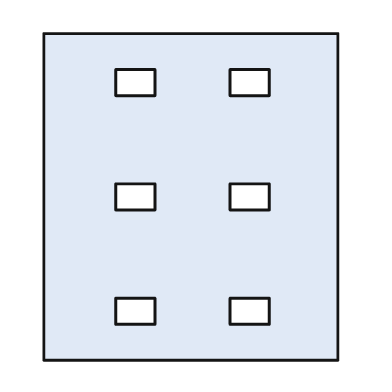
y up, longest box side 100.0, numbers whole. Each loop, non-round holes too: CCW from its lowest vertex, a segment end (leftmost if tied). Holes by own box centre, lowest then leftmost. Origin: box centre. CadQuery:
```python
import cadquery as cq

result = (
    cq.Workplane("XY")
    .moveTo(-45.0, -50.0)
    .lineTo(45.0, -50.0)
    .lineTo(45.0, 50.0)
    .lineTo(-45.0, 50.0)
    .close()
    .moveTo(-23.0, -39.0)
    .lineTo(-11.0, -39.0)
    .lineTo(-11.0, -31.0)
    .lineTo(-23.0, -31.0)
    .close()
    .moveTo(12.0, -39.0)
    .lineTo(24.0, -39.0)
    .lineTo(24.0, -31.0)
    .lineTo(12.0, -31.0)
    .close()
    .moveTo(-23.0, -4.0)
    .lineTo(-11.0, -4.0)
    .lineTo(-11.0, 4.0)
    .lineTo(-23.0, 4.0)
    .close()
    .moveTo(12.0, -4.0)
    .lineTo(24.0, -4.0)
    .lineTo(24.0, 4.0)
    .lineTo(12.0, 4.0)
    .close()
    .moveTo(-23.0, 31.0)
    .lineTo(-11.0, 31.0)
    .lineTo(-11.0, 39.0)
    .lineTo(-23.0, 39.0)
    .close()
    .moveTo(12.0, 31.0)
    .lineTo(24.0, 31.0)
    .lineTo(24.0, 39.0)
    .lineTo(12.0, 39.0)
    .close()
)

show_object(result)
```